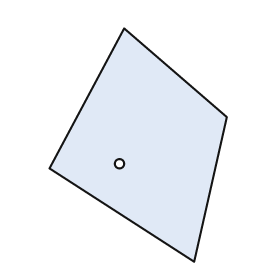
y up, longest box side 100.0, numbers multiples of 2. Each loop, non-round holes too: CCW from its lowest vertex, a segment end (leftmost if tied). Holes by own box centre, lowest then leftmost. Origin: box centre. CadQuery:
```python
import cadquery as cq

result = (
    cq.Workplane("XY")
    .moveTo(24.0, -50.0)
    .lineTo(38.0, 12.0)
    .lineTo(-6.0, 50.0)
    .lineTo(-38.0, -10.0)
    .close()
    .moveTo(-8.0, -8.0)
    .circle(2.0)
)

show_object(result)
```